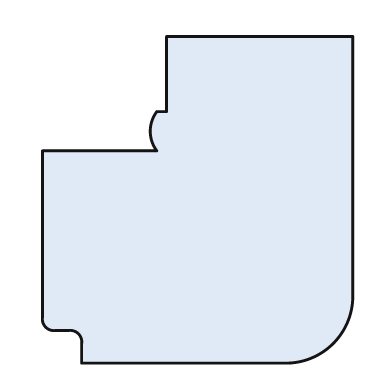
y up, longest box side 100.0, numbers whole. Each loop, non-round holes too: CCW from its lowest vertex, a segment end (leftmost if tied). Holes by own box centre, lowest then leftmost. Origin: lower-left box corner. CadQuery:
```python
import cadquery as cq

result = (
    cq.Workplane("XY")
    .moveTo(12.0, 0.0)
    .lineTo(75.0, 0.0)
    .threePointArc((89.0, 6.0), (95.0, 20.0))
    .lineTo(95.0, 100.0)
    .lineTo(38.0, 100.0)
    .lineTo(38.0, 77.0)
    .lineTo(35.0, 77.0)
    .threePointArc((33.0, 71.0), (35.0, 65.0))
    .lineTo(0.0, 65.0)
    .lineTo(0.0, 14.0)
    .threePointArc((1.0, 11.0), (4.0, 10.0))
    .lineTo(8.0, 10.0)
    .threePointArc((11.0, 9.0), (12.0, 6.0))
    .close()
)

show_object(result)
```